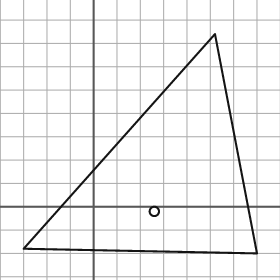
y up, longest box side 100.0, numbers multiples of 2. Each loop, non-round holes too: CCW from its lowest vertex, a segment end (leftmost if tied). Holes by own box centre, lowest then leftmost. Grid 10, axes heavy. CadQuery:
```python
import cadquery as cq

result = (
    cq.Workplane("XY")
    .moveTo(70.0, -20.0)
    .lineTo(52.0, 74.0)
    .lineTo(-30.0, -18.0)
    .close()
    .moveTo(26.0, -2.0)
    .circle(2.0)
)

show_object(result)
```